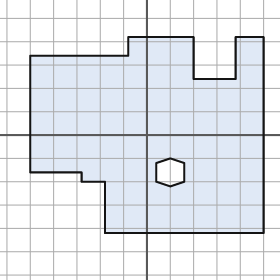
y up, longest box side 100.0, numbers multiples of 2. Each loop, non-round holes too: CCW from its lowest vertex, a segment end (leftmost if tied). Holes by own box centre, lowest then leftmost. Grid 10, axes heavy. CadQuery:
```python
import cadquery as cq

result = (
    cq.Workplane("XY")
    .moveTo(-18.0, -42.0)
    .lineTo(50.0, -42.0)
    .lineTo(50.0, 42.0)
    .lineTo(38.0, 42.0)
    .lineTo(38.0, 24.0)
    .lineTo(20.0, 24.0)
    .lineTo(20.0, 42.0)
    .lineTo(-8.0, 42.0)
    .lineTo(-8.0, 34.0)
    .lineTo(-50.0, 34.0)
    .lineTo(-50.0, -16.0)
    .lineTo(-28.0, -16.0)
    .lineTo(-28.0, -20.0)
    .lineTo(-18.0, -20.0)
    .close()
    .moveTo(10.0, -22.0)
    .lineTo(16.0, -20.0)
    .lineTo(16.0, -12.0)
    .lineTo(10.0, -10.0)
    .lineTo(4.0, -12.0)
    .lineTo(4.0, -20.0)
    .close()
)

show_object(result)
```